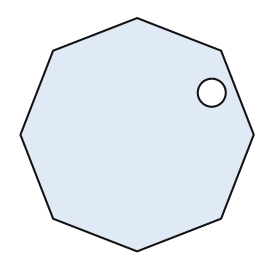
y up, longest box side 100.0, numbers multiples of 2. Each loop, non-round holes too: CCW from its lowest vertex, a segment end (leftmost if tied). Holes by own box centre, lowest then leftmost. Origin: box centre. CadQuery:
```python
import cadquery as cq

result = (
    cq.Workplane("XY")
    .moveTo(0.0, -50.0)
    .lineTo(36.0, -36.0)
    .lineTo(50.0, 0.0)
    .lineTo(36.0, 36.0)
    .lineTo(0.0, 50.0)
    .lineTo(-36.0, 36.0)
    .lineTo(-50.0, 0.0)
    .lineTo(-36.0, -36.0)
    .close()
    .moveTo(32.0, 18.0)
    .circle(6.0)
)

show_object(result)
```